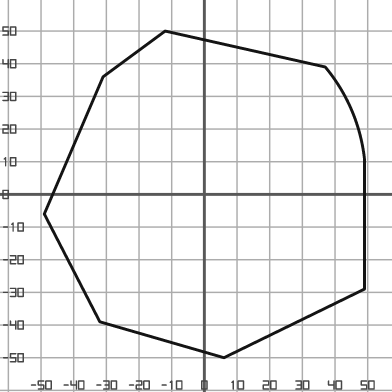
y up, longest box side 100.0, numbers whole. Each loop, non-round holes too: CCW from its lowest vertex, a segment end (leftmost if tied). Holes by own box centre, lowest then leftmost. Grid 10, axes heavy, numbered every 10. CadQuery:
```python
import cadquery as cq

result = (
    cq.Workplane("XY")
    .moveTo(6.0, -50.0)
    .lineTo(49.0, -29.0)
    .lineTo(49.0, 11.0)
    .threePointArc((45.0, 26.0), (37.0, 39.0))
    .lineTo(-12.0, 50.0)
    .lineTo(-31.0, 36.0)
    .lineTo(-49.0, -6.0)
    .lineTo(-32.0, -39.0)
    .close()
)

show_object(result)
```